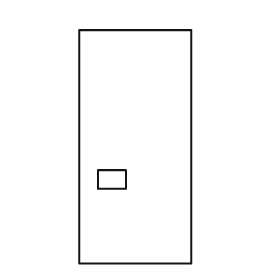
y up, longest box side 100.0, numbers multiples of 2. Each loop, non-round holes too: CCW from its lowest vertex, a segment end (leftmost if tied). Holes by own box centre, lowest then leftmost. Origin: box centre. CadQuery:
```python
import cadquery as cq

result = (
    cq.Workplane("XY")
    .moveTo(-24.0, -50.0)
    .lineTo(24.0, -50.0)
    .lineTo(24.0, 50.0)
    .lineTo(-24.0, 50.0)
    .close()
    .moveTo(-16.0, -18.0)
    .lineTo(-4.0, -18.0)
    .lineTo(-4.0, -10.0)
    .lineTo(-16.0, -10.0)
    .close()
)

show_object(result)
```